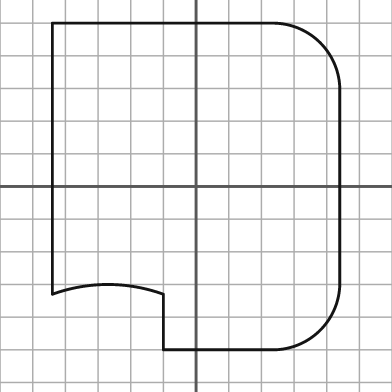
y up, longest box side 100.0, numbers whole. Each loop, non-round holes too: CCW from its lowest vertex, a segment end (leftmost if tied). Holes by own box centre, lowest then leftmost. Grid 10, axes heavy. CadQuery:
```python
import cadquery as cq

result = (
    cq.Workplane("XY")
    .moveTo(-10.0, -50.0)
    .lineTo(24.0, -50.0)
    .threePointArc((38.0, -44.0), (44.0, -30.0))
    .lineTo(44.0, 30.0)
    .threePointArc((38.0, 44.0), (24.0, 50.0))
    .lineTo(-44.0, 50.0)
    .lineTo(-44.0, -33.0)
    .threePointArc((-27.0, -30.0), (-10.0, -33.0))
    .close()
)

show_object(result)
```